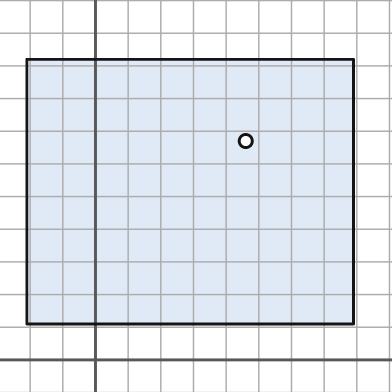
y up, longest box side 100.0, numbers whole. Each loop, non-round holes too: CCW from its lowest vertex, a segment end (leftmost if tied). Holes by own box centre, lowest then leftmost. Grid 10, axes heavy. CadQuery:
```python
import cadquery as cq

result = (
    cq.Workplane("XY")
    .moveTo(-21.0, 11.0)
    .lineTo(79.0, 11.0)
    .lineTo(79.0, 92.0)
    .lineTo(-21.0, 92.0)
    .close()
    .moveTo(46.0, 67.0)
    .circle(2.0)
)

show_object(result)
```